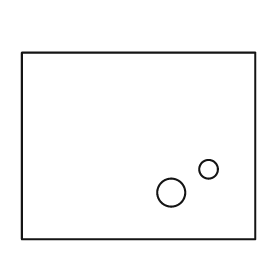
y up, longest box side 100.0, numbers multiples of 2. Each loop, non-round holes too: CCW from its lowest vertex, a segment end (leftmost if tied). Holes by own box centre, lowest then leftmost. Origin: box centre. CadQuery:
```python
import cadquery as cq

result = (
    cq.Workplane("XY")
    .moveTo(-50.0, -40.0)
    .lineTo(50.0, -40.0)
    .lineTo(50.0, 40.0)
    .lineTo(-50.0, 40.0)
    .close()
    .moveTo(14.0, -20.0)
    .circle(6.0)
    .moveTo(30.0, -10.0)
    .circle(4.0)
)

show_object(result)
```